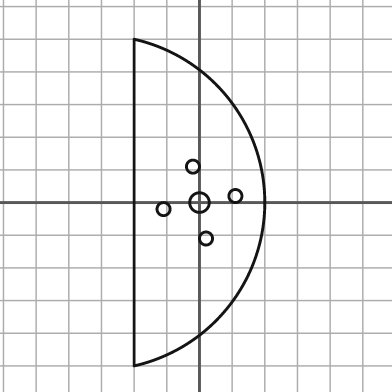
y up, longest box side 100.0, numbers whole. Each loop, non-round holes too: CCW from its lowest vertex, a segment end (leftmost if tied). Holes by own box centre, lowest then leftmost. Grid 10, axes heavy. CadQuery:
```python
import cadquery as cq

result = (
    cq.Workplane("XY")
    .moveTo(-20.0, -50.0)
    .threePointArc((20.0, 0.0), (-20.0, 50.0))
    .close()
    .moveTo(2.0, -11.0)
    .circle(2.0)
    .moveTo(-11.0, -2.0)
    .circle(2.0)
    .moveTo(0.0, 0.0)
    .circle(3.0)
    .moveTo(11.0, 2.0)
    .circle(2.0)
    .moveTo(-2.0, 11.0)
    .circle(2.0)
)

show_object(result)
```